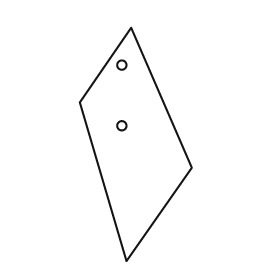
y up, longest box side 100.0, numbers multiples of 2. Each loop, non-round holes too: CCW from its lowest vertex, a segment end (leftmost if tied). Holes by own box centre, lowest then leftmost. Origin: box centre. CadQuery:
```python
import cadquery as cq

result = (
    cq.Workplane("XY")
    .moveTo(-4.0, -50.0)
    .lineTo(24.0, -10.0)
    .lineTo(-2.0, 50.0)
    .lineTo(-24.0, 18.0)
    .close()
    .moveTo(-6.0, 8.0)
    .circle(2.0)
    .moveTo(-6.0, 34.0)
    .circle(2.0)
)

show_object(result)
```